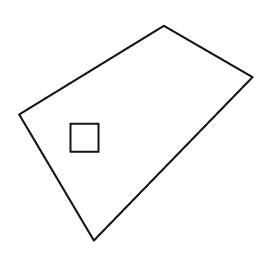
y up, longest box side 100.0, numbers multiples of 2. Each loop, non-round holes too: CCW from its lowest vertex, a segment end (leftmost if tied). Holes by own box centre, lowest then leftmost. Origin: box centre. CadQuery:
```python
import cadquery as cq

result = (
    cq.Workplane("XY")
    .moveTo(-18.0, -46.0)
    .lineTo(50.0, 24.0)
    .lineTo(12.0, 46.0)
    .lineTo(-50.0, 8.0)
    .close()
    .moveTo(-28.0, -8.0)
    .lineTo(-16.0, -8.0)
    .lineTo(-16.0, 4.0)
    .lineTo(-28.0, 4.0)
    .close()
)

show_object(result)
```